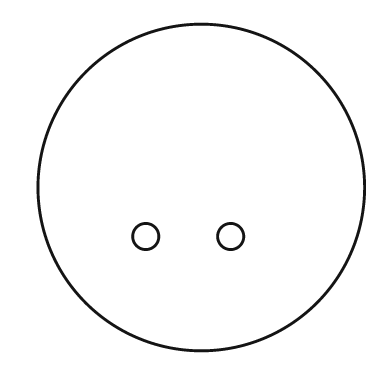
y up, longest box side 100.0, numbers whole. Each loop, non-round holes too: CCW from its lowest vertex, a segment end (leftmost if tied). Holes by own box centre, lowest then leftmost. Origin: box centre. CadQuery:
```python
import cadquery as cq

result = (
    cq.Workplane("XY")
    .moveTo(0.0, 0.0)
    .circle(50.0)
    .moveTo(-17.0, -15.0)
    .circle(4.0)
    .moveTo(9.0, -15.0)
    .circle(4.0)
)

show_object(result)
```